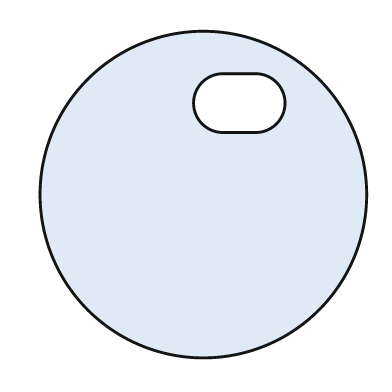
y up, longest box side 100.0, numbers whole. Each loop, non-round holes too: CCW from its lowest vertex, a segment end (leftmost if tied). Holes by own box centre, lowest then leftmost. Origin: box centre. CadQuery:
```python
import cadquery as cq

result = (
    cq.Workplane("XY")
    .moveTo(0.0, 0.0)
    .circle(50.0)
    .moveTo(6.0, 19.0)
    .lineTo(16.0, 19.0)
    .threePointArc((25.0, 28.0), (16.0, 37.0))
    .lineTo(6.0, 37.0)
    .threePointArc((-3.0, 28.0), (6.0, 19.0))
    .close()
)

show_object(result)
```